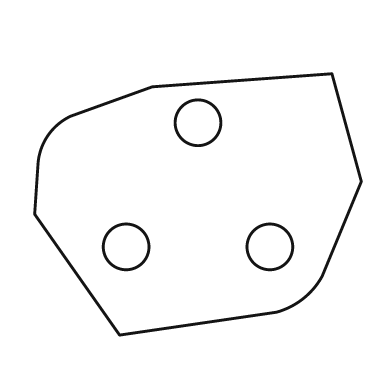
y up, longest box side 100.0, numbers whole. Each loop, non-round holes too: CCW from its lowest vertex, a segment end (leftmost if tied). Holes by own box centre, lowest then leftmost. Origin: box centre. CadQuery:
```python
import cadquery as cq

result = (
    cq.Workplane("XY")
    .moveTo(-24.0, -40.0)
    .lineTo(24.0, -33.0)
    .threePointArc((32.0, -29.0), (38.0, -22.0))
    .lineTo(50.0, 7.0)
    .lineTo(41.0, 40.0)
    .lineTo(-14.0, 36.0)
    .lineTo(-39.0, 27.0)
    .threePointArc((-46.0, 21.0), (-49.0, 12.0))
    .lineTo(-50.0, -3.0)
    .close()
    .moveTo(-22.0, -13.0)
    .circle(7.0)
    .moveTo(22.0, -13.0)
    .circle(7.0)
    .moveTo(0.0, 25.0)
    .circle(7.0)
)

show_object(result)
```